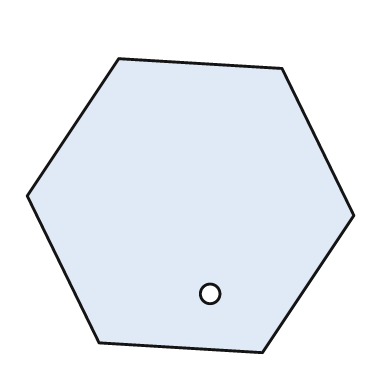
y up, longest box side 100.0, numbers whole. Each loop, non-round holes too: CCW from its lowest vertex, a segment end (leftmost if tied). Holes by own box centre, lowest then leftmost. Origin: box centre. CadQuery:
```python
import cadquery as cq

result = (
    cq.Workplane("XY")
    .moveTo(22.0, -45.0)
    .lineTo(50.0, -3.0)
    .lineTo(28.0, 42.0)
    .lineTo(-22.0, 45.0)
    .lineTo(-50.0, 3.0)
    .lineTo(-28.0, -42.0)
    .close()
    .moveTo(6.0, -27.0)
    .circle(3.0)
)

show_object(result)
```